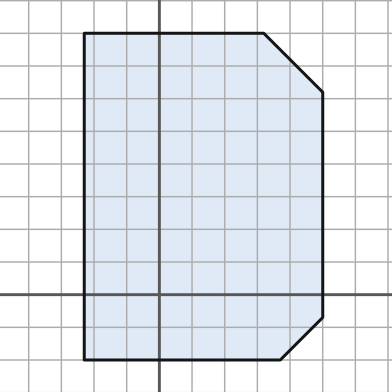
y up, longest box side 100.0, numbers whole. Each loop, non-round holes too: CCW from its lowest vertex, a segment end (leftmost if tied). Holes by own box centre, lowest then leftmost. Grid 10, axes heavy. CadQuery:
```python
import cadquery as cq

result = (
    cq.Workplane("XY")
    .moveTo(-23.0, -20.0)
    .lineTo(37.0, -20.0)
    .lineTo(50.0, -7.0)
    .lineTo(50.0, 62.0)
    .lineTo(32.0, 80.0)
    .lineTo(-23.0, 80.0)
    .close()
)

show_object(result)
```